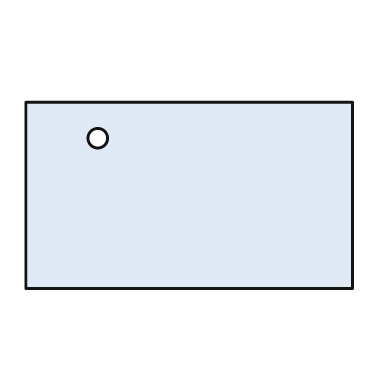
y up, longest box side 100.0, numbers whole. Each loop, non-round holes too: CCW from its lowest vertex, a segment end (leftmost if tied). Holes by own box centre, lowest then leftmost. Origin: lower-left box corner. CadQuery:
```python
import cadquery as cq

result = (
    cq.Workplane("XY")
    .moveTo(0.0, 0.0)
    .lineTo(100.0, 0.0)
    .lineTo(100.0, 57.0)
    .lineTo(0.0, 57.0)
    .close()
    .moveTo(22.0, 46.0)
    .circle(3.0)
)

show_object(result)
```